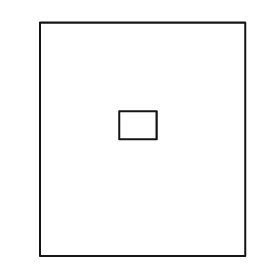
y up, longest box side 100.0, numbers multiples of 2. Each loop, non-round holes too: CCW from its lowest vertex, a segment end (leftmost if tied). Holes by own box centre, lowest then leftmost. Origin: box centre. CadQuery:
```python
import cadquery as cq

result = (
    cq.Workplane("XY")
    .moveTo(-44.0, -50.0)
    .lineTo(44.0, -50.0)
    .lineTo(44.0, 50.0)
    .lineTo(-44.0, 50.0)
    .close()
    .moveTo(-10.0, 0.0)
    .lineTo(6.0, 0.0)
    .lineTo(6.0, 12.0)
    .lineTo(-10.0, 12.0)
    .close()
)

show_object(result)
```